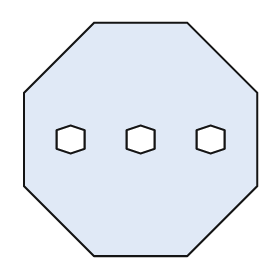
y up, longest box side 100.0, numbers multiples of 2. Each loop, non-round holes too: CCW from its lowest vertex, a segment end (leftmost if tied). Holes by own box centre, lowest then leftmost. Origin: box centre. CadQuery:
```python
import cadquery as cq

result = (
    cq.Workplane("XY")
    .moveTo(-20.0, -50.0)
    .lineTo(20.0, -50.0)
    .lineTo(50.0, -20.0)
    .lineTo(50.0, 20.0)
    .lineTo(20.0, 50.0)
    .lineTo(-20.0, 50.0)
    .lineTo(-50.0, 20.0)
    .lineTo(-50.0, -20.0)
    .close()
    .moveTo(-30.0, -6.0)
    .lineTo(-24.0, -4.0)
    .lineTo(-24.0, 4.0)
    .lineTo(-30.0, 6.0)
    .lineTo(-36.0, 4.0)
    .lineTo(-36.0, -4.0)
    .close()
    .moveTo(0.0, -6.0)
    .lineTo(6.0, -4.0)
    .lineTo(6.0, 4.0)
    .lineTo(0.0, 6.0)
    .lineTo(-6.0, 4.0)
    .lineTo(-6.0, -4.0)
    .close()
    .moveTo(30.0, -6.0)
    .lineTo(36.0, -4.0)
    .lineTo(36.0, 4.0)
    .lineTo(30.0, 6.0)
    .lineTo(24.0, 4.0)
    .lineTo(24.0, -4.0)
    .close()
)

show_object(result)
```